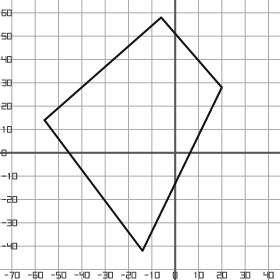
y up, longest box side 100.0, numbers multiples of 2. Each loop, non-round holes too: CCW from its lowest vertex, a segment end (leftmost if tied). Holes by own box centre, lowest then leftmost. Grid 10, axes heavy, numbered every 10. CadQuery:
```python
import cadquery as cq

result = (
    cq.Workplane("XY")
    .moveTo(-14.0, -42.0)
    .lineTo(20.0, 28.0)
    .lineTo(-6.0, 58.0)
    .lineTo(-56.0, 14.0)
    .close()
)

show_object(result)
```